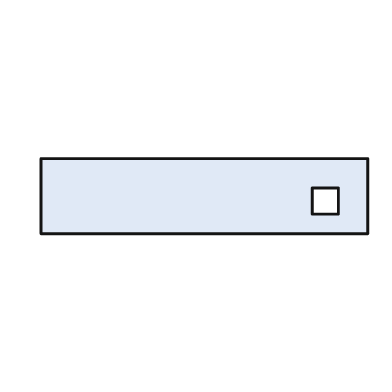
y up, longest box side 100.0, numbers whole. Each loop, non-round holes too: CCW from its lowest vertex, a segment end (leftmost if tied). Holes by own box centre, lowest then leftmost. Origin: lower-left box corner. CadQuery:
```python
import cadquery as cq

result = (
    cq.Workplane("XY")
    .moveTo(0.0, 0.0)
    .lineTo(100.0, 0.0)
    .lineTo(100.0, 23.0)
    .lineTo(0.0, 23.0)
    .close()
    .moveTo(83.0, 6.0)
    .lineTo(91.0, 6.0)
    .lineTo(91.0, 14.0)
    .lineTo(83.0, 14.0)
    .close()
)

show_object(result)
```